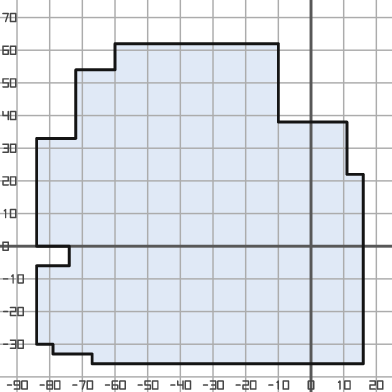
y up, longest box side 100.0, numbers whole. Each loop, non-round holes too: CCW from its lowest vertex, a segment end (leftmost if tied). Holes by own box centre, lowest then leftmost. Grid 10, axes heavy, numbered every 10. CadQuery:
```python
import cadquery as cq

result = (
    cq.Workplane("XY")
    .moveTo(-67.0, -36.0)
    .lineTo(16.0, -36.0)
    .lineTo(16.0, 22.0)
    .lineTo(11.0, 22.0)
    .lineTo(11.0, 38.0)
    .lineTo(-10.0, 38.0)
    .lineTo(-10.0, 62.0)
    .lineTo(-60.0, 62.0)
    .lineTo(-60.0, 54.0)
    .lineTo(-72.0, 54.0)
    .lineTo(-72.0, 33.0)
    .lineTo(-84.0, 33.0)
    .lineTo(-84.0, 0.0)
    .lineTo(-74.0, 0.0)
    .lineTo(-74.0, -6.0)
    .lineTo(-84.0, -6.0)
    .lineTo(-84.0, -30.0)
    .lineTo(-79.0, -30.0)
    .lineTo(-79.0, -33.0)
    .lineTo(-67.0, -33.0)
    .close()
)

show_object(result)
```